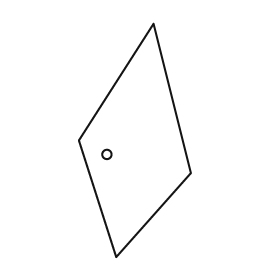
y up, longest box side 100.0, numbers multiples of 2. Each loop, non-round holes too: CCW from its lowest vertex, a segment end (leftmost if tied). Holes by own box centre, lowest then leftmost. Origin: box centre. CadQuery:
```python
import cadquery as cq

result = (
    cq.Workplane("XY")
    .moveTo(-8.0, -50.0)
    .lineTo(24.0, -14.0)
    .lineTo(8.0, 50.0)
    .lineTo(-24.0, 0.0)
    .close()
    .moveTo(-12.0, -6.0)
    .circle(2.0)
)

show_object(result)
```